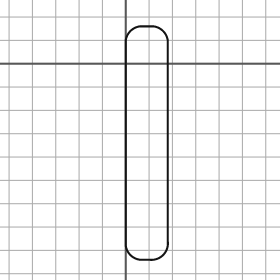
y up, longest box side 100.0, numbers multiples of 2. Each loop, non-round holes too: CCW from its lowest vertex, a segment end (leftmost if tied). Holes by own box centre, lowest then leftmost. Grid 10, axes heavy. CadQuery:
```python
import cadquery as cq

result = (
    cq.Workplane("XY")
    .moveTo(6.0, -84.0)
    .lineTo(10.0, -84.0)
    .threePointArc((16.0, -82.0), (18.0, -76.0))
    .lineTo(18.0, 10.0)
    .threePointArc((16.0, 14.0), (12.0, 16.0))
    .lineTo(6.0, 16.0)
    .threePointArc((2.0, 14.0), (0.0, 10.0))
    .lineTo(0.0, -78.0)
    .threePointArc((2.0, -82.0), (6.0, -84.0))
    .close()
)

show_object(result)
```